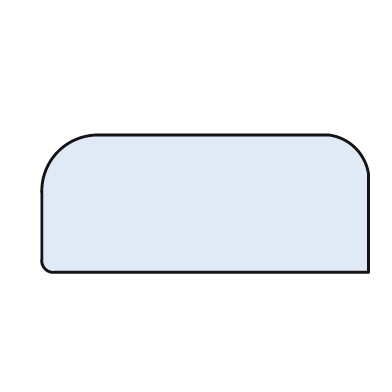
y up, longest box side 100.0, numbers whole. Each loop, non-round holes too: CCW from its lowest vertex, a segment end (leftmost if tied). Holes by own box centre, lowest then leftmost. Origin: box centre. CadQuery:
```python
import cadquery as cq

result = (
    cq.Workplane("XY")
    .moveTo(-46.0, -21.0)
    .lineTo(50.0, -21.0)
    .lineTo(50.0, 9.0)
    .threePointArc((46.0, 17.0), (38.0, 21.0))
    .lineTo(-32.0, 21.0)
    .threePointArc((-45.0, 16.0), (-50.0, 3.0))
    .lineTo(-50.0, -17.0)
    .threePointArc((-49.0, -20.0), (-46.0, -21.0))
    .close()
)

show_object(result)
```